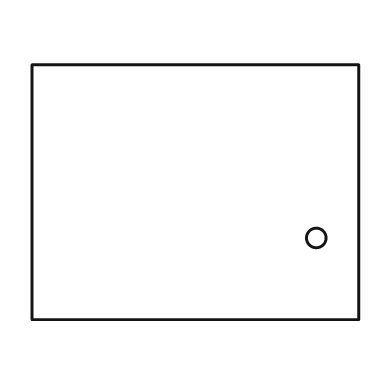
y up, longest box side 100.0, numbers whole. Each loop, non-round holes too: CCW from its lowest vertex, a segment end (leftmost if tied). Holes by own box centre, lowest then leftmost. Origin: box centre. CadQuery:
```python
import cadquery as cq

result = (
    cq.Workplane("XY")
    .moveTo(-50.0, -39.0)
    .lineTo(50.0, -39.0)
    .lineTo(50.0, 39.0)
    .lineTo(-50.0, 39.0)
    .close()
    .moveTo(37.0, -14.0)
    .circle(3.0)
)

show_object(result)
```